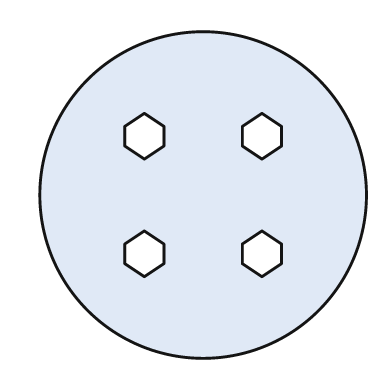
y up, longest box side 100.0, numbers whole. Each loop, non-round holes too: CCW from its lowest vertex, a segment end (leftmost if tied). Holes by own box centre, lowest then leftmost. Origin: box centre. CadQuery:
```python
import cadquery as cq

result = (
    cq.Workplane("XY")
    .moveTo(0.0, 0.0)
    .circle(50.0)
    .moveTo(-18.0, -25.0)
    .lineTo(-12.0, -21.0)
    .lineTo(-12.0, -15.0)
    .lineTo(-18.0, -11.0)
    .lineTo(-24.0, -15.0)
    .lineTo(-24.0, -21.0)
    .close()
    .moveTo(18.0, -25.0)
    .lineTo(24.0, -21.0)
    .lineTo(24.0, -15.0)
    .lineTo(18.0, -11.0)
    .lineTo(12.0, -15.0)
    .lineTo(12.0, -21.0)
    .close()
    .moveTo(-18.0, 11.0)
    .lineTo(-12.0, 15.0)
    .lineTo(-12.0, 21.0)
    .lineTo(-18.0, 25.0)
    .lineTo(-24.0, 21.0)
    .lineTo(-24.0, 15.0)
    .close()
    .moveTo(18.0, 11.0)
    .lineTo(24.0, 15.0)
    .lineTo(24.0, 21.0)
    .lineTo(18.0, 25.0)
    .lineTo(12.0, 21.0)
    .lineTo(12.0, 15.0)
    .close()
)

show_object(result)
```